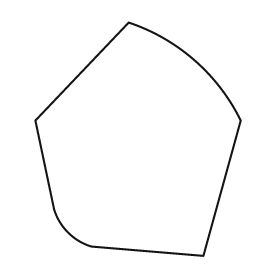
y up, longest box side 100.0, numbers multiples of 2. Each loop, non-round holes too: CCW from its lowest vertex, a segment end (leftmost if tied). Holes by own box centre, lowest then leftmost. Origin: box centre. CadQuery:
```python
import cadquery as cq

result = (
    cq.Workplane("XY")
    .moveTo(28.0, -50.0)
    .lineTo(44.0, 8.0)
    .threePointArc((24.0, 34.0), (-4.0, 50.0))
    .lineTo(-44.0, 8.0)
    .lineTo(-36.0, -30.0)
    .threePointArc((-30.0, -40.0), (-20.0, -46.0))
    .close()
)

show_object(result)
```